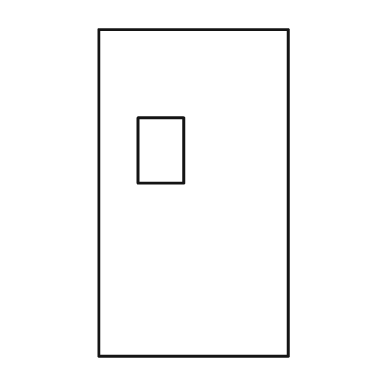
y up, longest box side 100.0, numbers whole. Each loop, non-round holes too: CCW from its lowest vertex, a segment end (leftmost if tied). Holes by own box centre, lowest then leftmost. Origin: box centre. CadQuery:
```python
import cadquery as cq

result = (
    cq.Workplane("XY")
    .moveTo(-29.0, -50.0)
    .lineTo(29.0, -50.0)
    .lineTo(29.0, 50.0)
    .lineTo(-29.0, 50.0)
    .close()
    .moveTo(-17.0, 3.0)
    .lineTo(-3.0, 3.0)
    .lineTo(-3.0, 23.0)
    .lineTo(-17.0, 23.0)
    .close()
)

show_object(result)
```